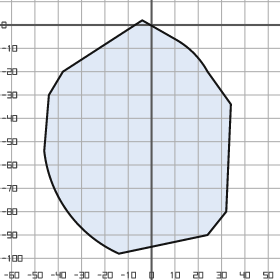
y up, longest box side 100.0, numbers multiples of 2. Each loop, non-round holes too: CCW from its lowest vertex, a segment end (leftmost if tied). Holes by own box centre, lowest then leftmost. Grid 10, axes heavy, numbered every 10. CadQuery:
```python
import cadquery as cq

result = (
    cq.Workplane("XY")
    .moveTo(-14.0, -98.0)
    .lineTo(24.0, -90.0)
    .lineTo(32.0, -80.0)
    .lineTo(34.0, -34.0)
    .lineTo(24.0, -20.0)
    .threePointArc((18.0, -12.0), (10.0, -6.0))
    .lineTo(-4.0, 2.0)
    .lineTo(-38.0, -20.0)
    .lineTo(-44.0, -30.0)
    .lineTo(-46.0, -54.0)
    .threePointArc((-36.0, -80.0), (-14.0, -98.0))
    .close()
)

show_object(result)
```